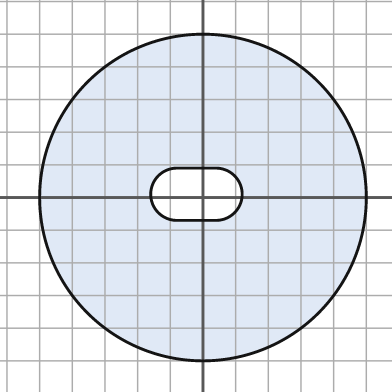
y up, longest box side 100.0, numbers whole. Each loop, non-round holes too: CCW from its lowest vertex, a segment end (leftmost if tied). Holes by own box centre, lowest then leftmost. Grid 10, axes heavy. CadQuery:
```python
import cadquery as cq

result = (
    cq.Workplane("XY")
    .moveTo(0.0, 0.0)
    .circle(50.0)
    .moveTo(-8.0, -7.0)
    .lineTo(4.0, -7.0)
    .threePointArc((12.0, 1.0), (4.0, 9.0))
    .lineTo(-8.0, 9.0)
    .threePointArc((-16.0, 1.0), (-8.0, -7.0))
    .close()
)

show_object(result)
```